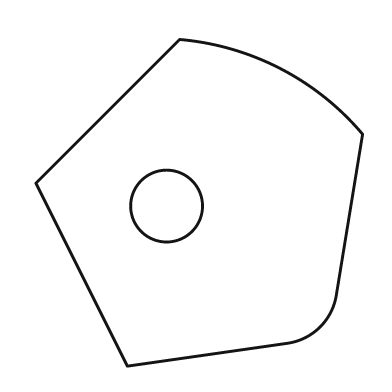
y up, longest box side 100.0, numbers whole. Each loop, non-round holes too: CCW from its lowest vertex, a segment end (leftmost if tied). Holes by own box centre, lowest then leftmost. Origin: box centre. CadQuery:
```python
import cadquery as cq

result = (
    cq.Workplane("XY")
    .moveTo(-22.0, -50.0)
    .lineTo(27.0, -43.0)
    .threePointArc((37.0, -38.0), (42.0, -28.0))
    .lineTo(50.0, 21.0)
    .threePointArc((25.0, 41.0), (-6.0, 50.0))
    .lineTo(-50.0, 6.0)
    .close()
    .moveTo(-10.0, -1.0)
    .circle(11.0)
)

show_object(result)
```